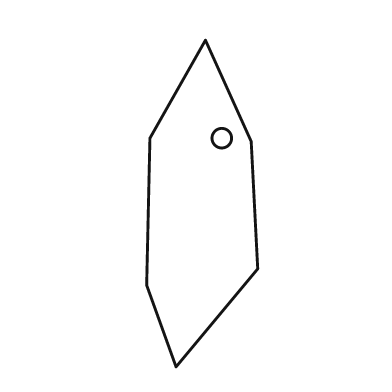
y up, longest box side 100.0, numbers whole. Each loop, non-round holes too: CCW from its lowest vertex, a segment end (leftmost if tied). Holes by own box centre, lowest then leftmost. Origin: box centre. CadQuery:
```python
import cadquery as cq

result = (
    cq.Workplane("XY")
    .moveTo(-8.0, -50.0)
    .lineTo(17.0, -20.0)
    .lineTo(15.0, 19.0)
    .lineTo(1.0, 50.0)
    .lineTo(-16.0, 20.0)
    .lineTo(-17.0, -25.0)
    .close()
    .moveTo(6.0, 20.0)
    .circle(3.0)
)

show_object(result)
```